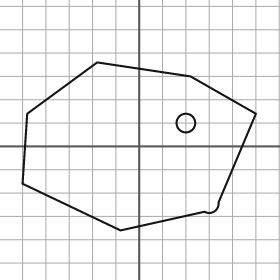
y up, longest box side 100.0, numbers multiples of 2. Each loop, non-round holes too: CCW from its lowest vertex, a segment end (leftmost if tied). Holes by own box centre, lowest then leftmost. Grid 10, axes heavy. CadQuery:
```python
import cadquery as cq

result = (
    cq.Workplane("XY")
    .moveTo(-8.0, -36.0)
    .lineTo(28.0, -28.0)
    .threePointArc((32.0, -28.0), (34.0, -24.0))
    .lineTo(50.0, 14.0)
    .lineTo(22.0, 30.0)
    .lineTo(-18.0, 36.0)
    .lineTo(-48.0, 14.0)
    .lineTo(-50.0, -16.0)
    .close()
    .moveTo(20.0, 10.0)
    .circle(4.0)
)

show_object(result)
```